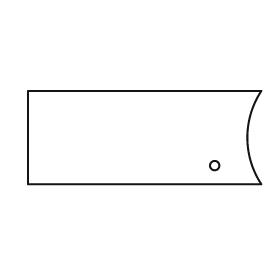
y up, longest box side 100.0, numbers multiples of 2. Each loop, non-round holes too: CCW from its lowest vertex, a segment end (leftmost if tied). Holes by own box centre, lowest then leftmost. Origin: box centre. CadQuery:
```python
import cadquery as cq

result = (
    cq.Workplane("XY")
    .moveTo(-50.0, -20.0)
    .lineTo(50.0, -20.0)
    .threePointArc((44.0, 0.0), (50.0, 20.0))
    .lineTo(-50.0, 20.0)
    .close()
    .moveTo(30.0, -12.0)
    .circle(2.0)
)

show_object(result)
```